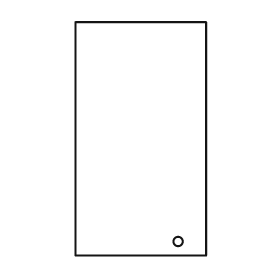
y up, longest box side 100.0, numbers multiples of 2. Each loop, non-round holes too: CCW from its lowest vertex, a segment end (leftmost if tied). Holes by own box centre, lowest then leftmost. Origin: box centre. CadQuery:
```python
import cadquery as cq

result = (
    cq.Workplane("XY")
    .moveTo(-28.0, -50.0)
    .lineTo(28.0, -50.0)
    .lineTo(28.0, 50.0)
    .lineTo(-28.0, 50.0)
    .close()
    .moveTo(16.0, -44.0)
    .circle(2.0)
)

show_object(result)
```